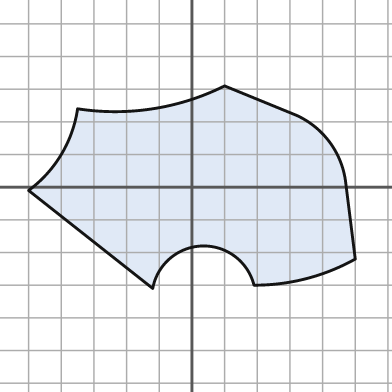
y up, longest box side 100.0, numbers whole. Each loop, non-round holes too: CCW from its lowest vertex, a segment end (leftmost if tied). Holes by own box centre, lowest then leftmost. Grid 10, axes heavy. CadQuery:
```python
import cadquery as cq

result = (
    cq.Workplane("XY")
    .moveTo(-12.0, -31.0)
    .threePointArc((3.0, -18.0), (19.0, -30.0))
    .threePointArc((35.0, -28.0), (50.0, -22.0))
    .lineTo(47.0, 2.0)
    .threePointArc((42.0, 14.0), (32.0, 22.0))
    .lineTo(10.0, 31.0)
    .threePointArc((-12.0, 24.0), (-35.0, 24.0))
    .threePointArc((-40.0, 10.0), (-50.0, -1.0))
    .close()
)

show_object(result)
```